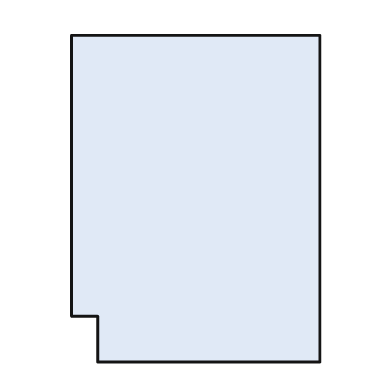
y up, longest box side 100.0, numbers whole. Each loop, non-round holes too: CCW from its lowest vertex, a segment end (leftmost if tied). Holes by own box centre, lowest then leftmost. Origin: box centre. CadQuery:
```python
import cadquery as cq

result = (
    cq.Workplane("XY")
    .moveTo(-30.0, -50.0)
    .lineTo(38.0, -50.0)
    .lineTo(38.0, 50.0)
    .lineTo(-38.0, 50.0)
    .lineTo(-38.0, -36.0)
    .lineTo(-30.0, -36.0)
    .close()
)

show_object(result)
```